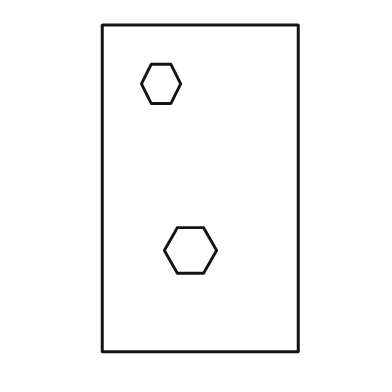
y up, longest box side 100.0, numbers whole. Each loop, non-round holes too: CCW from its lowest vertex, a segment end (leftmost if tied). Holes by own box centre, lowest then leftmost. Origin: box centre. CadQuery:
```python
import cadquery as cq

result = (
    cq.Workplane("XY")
    .moveTo(-30.0, -50.0)
    .lineTo(30.0, -50.0)
    .lineTo(30.0, 50.0)
    .lineTo(-30.0, 50.0)
    .close()
    .moveTo(-7.0, -26.0)
    .lineTo(1.0, -26.0)
    .lineTo(5.0, -19.0)
    .lineTo(1.0, -12.0)
    .lineTo(-7.0, -12.0)
    .lineTo(-11.0, -19.0)
    .close()
    .moveTo(-15.0, 26.0)
    .lineTo(-9.0, 26.0)
    .lineTo(-6.0, 32.0)
    .lineTo(-9.0, 38.0)
    .lineTo(-15.0, 38.0)
    .lineTo(-18.0, 32.0)
    .close()
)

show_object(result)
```